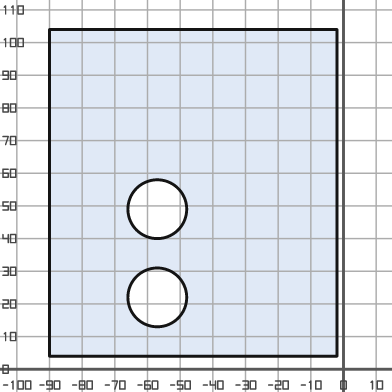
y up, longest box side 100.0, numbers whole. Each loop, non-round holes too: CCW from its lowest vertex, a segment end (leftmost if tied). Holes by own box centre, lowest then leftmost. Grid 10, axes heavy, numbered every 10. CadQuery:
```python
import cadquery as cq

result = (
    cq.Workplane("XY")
    .moveTo(-90.0, 4.0)
    .lineTo(-2.0, 4.0)
    .lineTo(-2.0, 104.0)
    .lineTo(-90.0, 104.0)
    .close()
    .moveTo(-57.0, 22.0)
    .circle(9.0)
    .moveTo(-57.0, 49.0)
    .circle(9.0)
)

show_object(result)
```